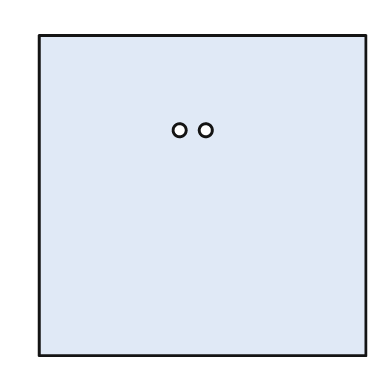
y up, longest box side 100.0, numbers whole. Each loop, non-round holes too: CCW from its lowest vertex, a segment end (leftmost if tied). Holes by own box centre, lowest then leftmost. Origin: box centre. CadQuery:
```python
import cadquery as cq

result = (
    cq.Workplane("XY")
    .moveTo(-50.0, -49.0)
    .lineTo(50.0, -49.0)
    .lineTo(50.0, 49.0)
    .lineTo(-50.0, 49.0)
    .close()
    .moveTo(-7.0, 20.0)
    .circle(2.0)
    .moveTo(1.0, 20.0)
    .circle(2.0)
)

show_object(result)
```